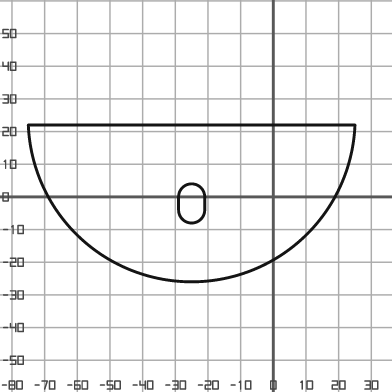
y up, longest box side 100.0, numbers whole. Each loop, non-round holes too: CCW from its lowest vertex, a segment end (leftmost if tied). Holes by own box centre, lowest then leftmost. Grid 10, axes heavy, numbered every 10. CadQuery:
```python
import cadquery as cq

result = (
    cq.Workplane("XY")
    .moveTo(-75.0, 22.0)
    .threePointArc((-25.0, -26.0), (25.0, 22.0))
    .close()
    .moveTo(-29.0, -4.0)
    .threePointArc((-25.0, -8.0), (-21.0, -4.0))
    .lineTo(-21.0, 0.0)
    .threePointArc((-25.0, 4.0), (-29.0, 0.0))
    .close()
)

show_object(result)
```